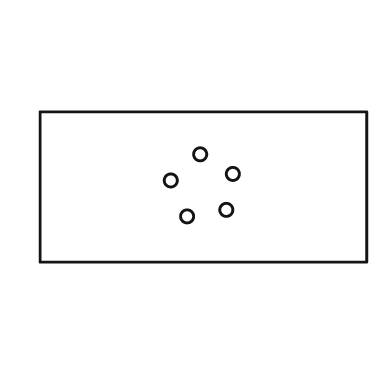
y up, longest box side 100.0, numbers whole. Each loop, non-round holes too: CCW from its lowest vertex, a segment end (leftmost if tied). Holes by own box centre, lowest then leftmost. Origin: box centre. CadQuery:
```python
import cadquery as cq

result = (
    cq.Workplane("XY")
    .moveTo(-50.0, -23.0)
    .lineTo(50.0, -23.0)
    .lineTo(50.0, 23.0)
    .lineTo(-50.0, 23.0)
    .close()
    .moveTo(-5.0, -9.0)
    .circle(2.0)
    .moveTo(7.0, -7.0)
    .circle(2.0)
    .moveTo(-10.0, 2.0)
    .circle(2.0)
    .moveTo(9.0, 4.0)
    .circle(2.0)
    .moveTo(-1.0, 10.0)
    .circle(2.0)
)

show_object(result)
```